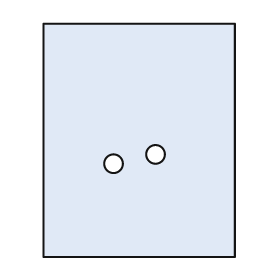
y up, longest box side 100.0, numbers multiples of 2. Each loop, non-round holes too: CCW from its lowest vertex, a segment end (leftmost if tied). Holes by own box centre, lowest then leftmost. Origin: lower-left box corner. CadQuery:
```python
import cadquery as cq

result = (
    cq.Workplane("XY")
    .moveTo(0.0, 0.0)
    .lineTo(82.0, 0.0)
    .lineTo(82.0, 100.0)
    .lineTo(0.0, 100.0)
    .close()
    .moveTo(30.0, 40.0)
    .circle(4.0)
    .moveTo(48.0, 44.0)
    .circle(4.0)
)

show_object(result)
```